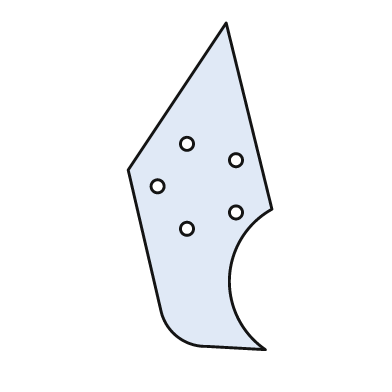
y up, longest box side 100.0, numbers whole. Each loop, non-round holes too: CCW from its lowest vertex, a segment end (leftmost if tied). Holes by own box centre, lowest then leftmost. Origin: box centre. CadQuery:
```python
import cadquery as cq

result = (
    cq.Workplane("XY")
    .moveTo(20.0, -50.0)
    .threePointArc((9.0, -28.0), (22.0, -7.0))
    .lineTo(8.0, 50.0)
    .lineTo(-22.0, 5.0)
    .lineTo(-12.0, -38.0)
    .threePointArc((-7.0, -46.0), (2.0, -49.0))
    .close()
    .moveTo(-4.0, -13.0)
    .circle(2.0)
    .moveTo(11.0, -8.0)
    .circle(2.0)
    .moveTo(-13.0, 0.0)
    .circle(2.0)
    .moveTo(11.0, 8.0)
    .circle(2.0)
    .moveTo(-4.0, 13.0)
    .circle(2.0)
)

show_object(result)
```